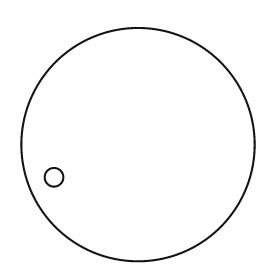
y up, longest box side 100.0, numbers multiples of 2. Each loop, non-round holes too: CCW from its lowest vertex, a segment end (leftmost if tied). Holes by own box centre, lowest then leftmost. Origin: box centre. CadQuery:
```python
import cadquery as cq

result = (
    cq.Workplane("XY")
    .moveTo(0.0, 0.0)
    .circle(50.0)
    .moveTo(-36.0, -14.0)
    .circle(4.0)
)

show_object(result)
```